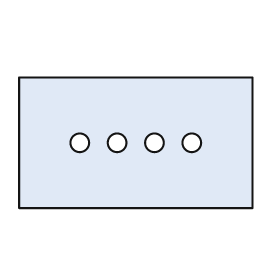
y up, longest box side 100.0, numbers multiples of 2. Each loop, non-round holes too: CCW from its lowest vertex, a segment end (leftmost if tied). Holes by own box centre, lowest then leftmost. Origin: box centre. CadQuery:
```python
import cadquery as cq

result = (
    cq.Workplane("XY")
    .moveTo(-50.0, -28.0)
    .lineTo(50.0, -28.0)
    .lineTo(50.0, 28.0)
    .lineTo(-50.0, 28.0)
    .close()
    .moveTo(-24.0, 0.0)
    .circle(4.0)
    .moveTo(-8.0, 0.0)
    .circle(4.0)
    .moveTo(8.0, 0.0)
    .circle(4.0)
    .moveTo(24.0, 0.0)
    .circle(4.0)
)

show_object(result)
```